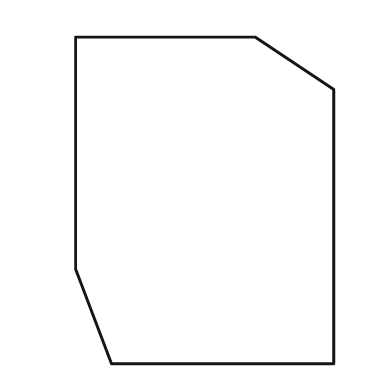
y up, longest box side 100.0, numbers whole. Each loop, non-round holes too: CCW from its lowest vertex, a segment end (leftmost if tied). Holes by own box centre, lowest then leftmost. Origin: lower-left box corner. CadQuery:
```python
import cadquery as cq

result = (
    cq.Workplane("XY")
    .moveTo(11.0, 0.0)
    .lineTo(79.0, 0.0)
    .lineTo(79.0, 84.0)
    .lineTo(55.0, 100.0)
    .lineTo(0.0, 100.0)
    .lineTo(0.0, 29.0)
    .close()
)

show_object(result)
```